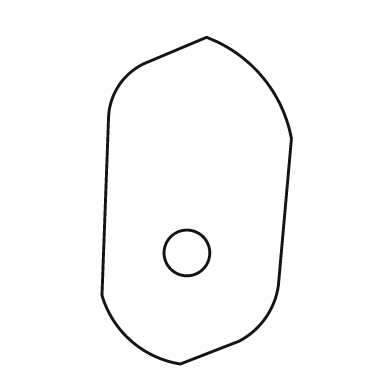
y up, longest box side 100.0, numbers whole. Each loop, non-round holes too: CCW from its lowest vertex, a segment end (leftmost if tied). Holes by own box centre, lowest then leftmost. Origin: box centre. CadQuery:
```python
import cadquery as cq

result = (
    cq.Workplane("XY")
    .moveTo(-5.0, -50.0)
    .lineTo(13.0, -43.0)
    .threePointArc((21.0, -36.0), (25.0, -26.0))
    .lineTo(29.0, 19.0)
    .threePointArc((20.0, 38.0), (3.0, 50.0))
    .lineTo(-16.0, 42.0)
    .threePointArc((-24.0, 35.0), (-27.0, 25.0))
    .lineTo(-29.0, -29.0)
    .threePointArc((-20.0, -43.0), (-5.0, -50.0))
    .close()
    .moveTo(-3.0, -16.0)
    .circle(7.0)
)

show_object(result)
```